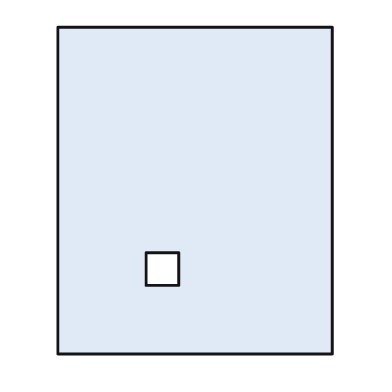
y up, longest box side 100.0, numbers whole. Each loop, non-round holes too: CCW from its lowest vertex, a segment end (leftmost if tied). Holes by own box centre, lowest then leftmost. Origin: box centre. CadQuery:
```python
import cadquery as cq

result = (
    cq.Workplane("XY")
    .moveTo(-42.0, -50.0)
    .lineTo(42.0, -50.0)
    .lineTo(42.0, 50.0)
    .lineTo(-42.0, 50.0)
    .close()
    .moveTo(-15.0, -29.0)
    .lineTo(-5.0, -29.0)
    .lineTo(-5.0, -19.0)
    .lineTo(-15.0, -19.0)
    .close()
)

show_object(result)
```